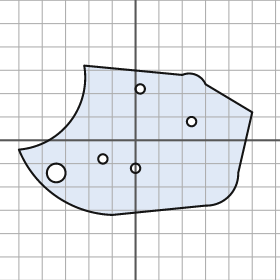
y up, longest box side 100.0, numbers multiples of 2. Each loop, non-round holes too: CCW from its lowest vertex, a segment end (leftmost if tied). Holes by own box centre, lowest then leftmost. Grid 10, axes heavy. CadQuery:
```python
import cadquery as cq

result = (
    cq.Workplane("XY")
    .moveTo(-10.0, -32.0)
    .lineTo(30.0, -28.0)
    .threePointArc((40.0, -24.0), (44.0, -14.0))
    .lineTo(50.0, 12.0)
    .lineTo(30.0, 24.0)
    .threePointArc((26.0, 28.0), (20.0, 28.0))
    .lineTo(-22.0, 32.0)
    .threePointArc((-28.0, 8.0), (-50.0, -4.0))
    .threePointArc((-34.0, -24.0), (-10.0, -32.0))
    .close()
    .moveTo(-34.0, -14.0)
    .circle(4.0)
    .moveTo(0.0, -12.0)
    .circle(2.0)
    .moveTo(-14.0, -8.0)
    .circle(2.0)
    .moveTo(24.0, 8.0)
    .circle(2.0)
    .moveTo(2.0, 22.0)
    .circle(2.0)
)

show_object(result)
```